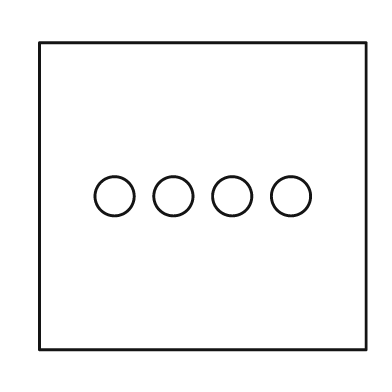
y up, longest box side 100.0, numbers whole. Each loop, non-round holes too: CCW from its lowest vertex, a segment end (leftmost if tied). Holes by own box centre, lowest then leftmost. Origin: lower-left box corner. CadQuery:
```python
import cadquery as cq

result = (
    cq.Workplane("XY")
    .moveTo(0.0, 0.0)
    .lineTo(100.0, 0.0)
    .lineTo(100.0, 94.0)
    .lineTo(0.0, 94.0)
    .close()
    .moveTo(23.0, 47.0)
    .circle(6.0)
    .moveTo(41.0, 47.0)
    .circle(6.0)
    .moveTo(59.0, 47.0)
    .circle(6.0)
    .moveTo(77.0, 47.0)
    .circle(6.0)
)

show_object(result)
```